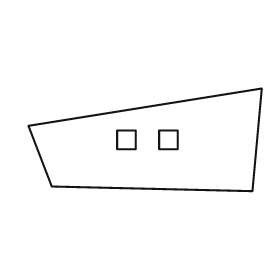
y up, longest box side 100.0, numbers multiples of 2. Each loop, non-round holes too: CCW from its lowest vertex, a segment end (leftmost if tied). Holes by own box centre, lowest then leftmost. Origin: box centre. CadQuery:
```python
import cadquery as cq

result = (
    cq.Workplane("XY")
    .moveTo(46.0, -22.0)
    .lineTo(50.0, 22.0)
    .lineTo(-50.0, 6.0)
    .lineTo(-40.0, -20.0)
    .close()
    .moveTo(-12.0, -4.0)
    .lineTo(-4.0, -4.0)
    .lineTo(-4.0, 4.0)
    .lineTo(-12.0, 4.0)
    .close()
    .moveTo(6.0, -4.0)
    .lineTo(14.0, -4.0)
    .lineTo(14.0, 4.0)
    .lineTo(6.0, 4.0)
    .close()
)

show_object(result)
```